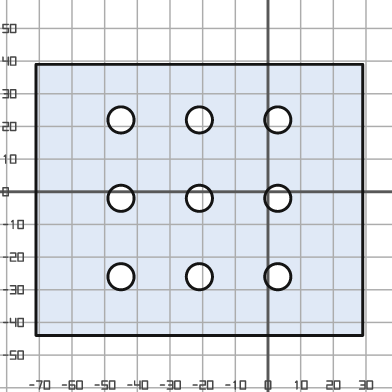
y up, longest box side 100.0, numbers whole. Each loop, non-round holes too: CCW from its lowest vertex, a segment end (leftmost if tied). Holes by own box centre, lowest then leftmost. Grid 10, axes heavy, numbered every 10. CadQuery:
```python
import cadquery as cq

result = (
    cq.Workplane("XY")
    .moveTo(-71.0, -44.0)
    .lineTo(29.0, -44.0)
    .lineTo(29.0, 39.0)
    .lineTo(-71.0, 39.0)
    .close()
    .moveTo(-45.0, -26.0)
    .circle(4.0)
    .moveTo(-21.0, -26.0)
    .circle(4.0)
    .moveTo(3.0, -26.0)
    .circle(4.0)
    .moveTo(-45.0, -2.0)
    .circle(4.0)
    .moveTo(-21.0, -2.0)
    .circle(4.0)
    .moveTo(3.0, -2.0)
    .circle(4.0)
    .moveTo(-45.0, 22.0)
    .circle(4.0)
    .moveTo(-21.0, 22.0)
    .circle(4.0)
    .moveTo(3.0, 22.0)
    .circle(4.0)
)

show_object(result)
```